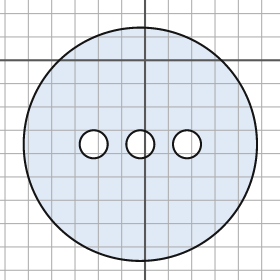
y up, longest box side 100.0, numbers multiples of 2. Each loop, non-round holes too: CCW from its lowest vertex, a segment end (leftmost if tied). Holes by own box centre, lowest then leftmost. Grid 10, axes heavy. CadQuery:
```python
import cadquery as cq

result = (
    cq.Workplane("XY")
    .moveTo(-2.0, -36.0)
    .circle(50.0)
    .moveTo(-22.0, -36.0)
    .circle(6.0)
    .moveTo(-2.0, -36.0)
    .circle(6.0)
    .moveTo(18.0, -36.0)
    .circle(6.0)
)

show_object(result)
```